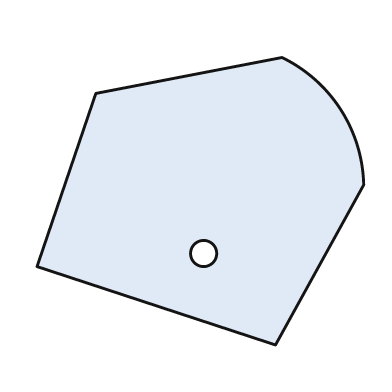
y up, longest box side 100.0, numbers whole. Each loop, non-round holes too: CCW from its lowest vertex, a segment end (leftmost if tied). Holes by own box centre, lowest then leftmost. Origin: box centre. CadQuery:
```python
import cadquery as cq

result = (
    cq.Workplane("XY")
    .moveTo(23.0, -44.0)
    .lineTo(50.0, 5.0)
    .threePointArc((43.0, 28.0), (25.0, 44.0))
    .lineTo(-32.0, 33.0)
    .lineTo(-50.0, -20.0)
    .close()
    .moveTo(1.0, -16.0)
    .circle(4.0)
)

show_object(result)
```